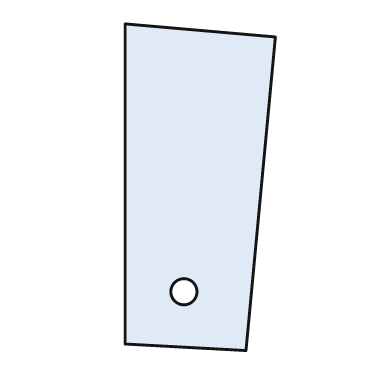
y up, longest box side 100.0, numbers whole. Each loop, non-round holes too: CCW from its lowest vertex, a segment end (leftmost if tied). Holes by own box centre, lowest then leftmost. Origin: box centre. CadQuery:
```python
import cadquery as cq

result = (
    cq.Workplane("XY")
    .moveTo(14.0, -50.0)
    .lineTo(23.0, 46.0)
    .lineTo(-23.0, 50.0)
    .lineTo(-23.0, -48.0)
    .close()
    .moveTo(-5.0, -32.0)
    .circle(4.0)
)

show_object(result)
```